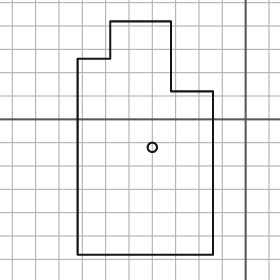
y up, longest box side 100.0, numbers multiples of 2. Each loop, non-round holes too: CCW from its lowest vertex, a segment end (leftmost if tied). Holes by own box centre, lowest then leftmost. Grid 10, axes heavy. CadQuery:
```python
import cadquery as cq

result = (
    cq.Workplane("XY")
    .moveTo(-72.0, -58.0)
    .lineTo(-14.0, -58.0)
    .lineTo(-14.0, 12.0)
    .lineTo(-32.0, 12.0)
    .lineTo(-32.0, 42.0)
    .lineTo(-58.0, 42.0)
    .lineTo(-58.0, 26.0)
    .lineTo(-72.0, 26.0)
    .close()
    .moveTo(-40.0, -12.0)
    .circle(2.0)
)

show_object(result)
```